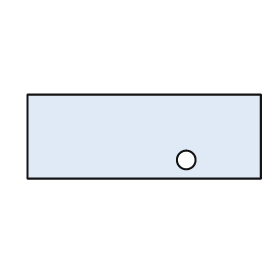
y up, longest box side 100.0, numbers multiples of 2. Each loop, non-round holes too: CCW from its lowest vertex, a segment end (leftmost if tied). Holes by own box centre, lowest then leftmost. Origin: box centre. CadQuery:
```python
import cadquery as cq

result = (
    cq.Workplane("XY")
    .moveTo(-50.0, -18.0)
    .lineTo(50.0, -18.0)
    .lineTo(50.0, 18.0)
    .lineTo(-50.0, 18.0)
    .close()
    .moveTo(18.0, -10.0)
    .circle(4.0)
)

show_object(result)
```